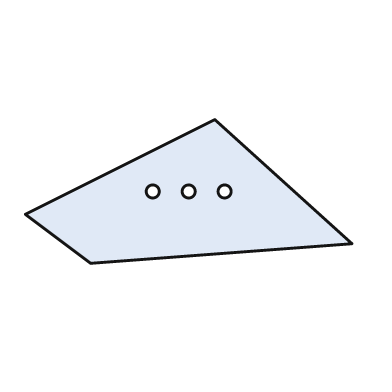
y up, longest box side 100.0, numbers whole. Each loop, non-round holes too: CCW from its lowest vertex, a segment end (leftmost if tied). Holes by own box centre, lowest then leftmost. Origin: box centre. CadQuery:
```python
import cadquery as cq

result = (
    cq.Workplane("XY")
    .moveTo(-30.0, -22.0)
    .lineTo(50.0, -16.0)
    .lineTo(8.0, 22.0)
    .lineTo(-50.0, -7.0)
    .close()
    .moveTo(-11.0, 0.0)
    .circle(2.0)
    .moveTo(0.0, 0.0)
    .circle(2.0)
    .moveTo(11.0, 0.0)
    .circle(2.0)
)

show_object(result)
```